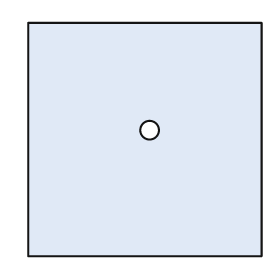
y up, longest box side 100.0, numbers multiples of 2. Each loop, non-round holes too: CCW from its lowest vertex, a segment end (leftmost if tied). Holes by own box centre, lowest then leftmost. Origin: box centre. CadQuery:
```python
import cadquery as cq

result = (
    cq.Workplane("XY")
    .moveTo(-50.0, -50.0)
    .lineTo(50.0, -50.0)
    .lineTo(50.0, 50.0)
    .lineTo(-50.0, 50.0)
    .close()
    .moveTo(2.0, 4.0)
    .circle(4.0)
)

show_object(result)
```